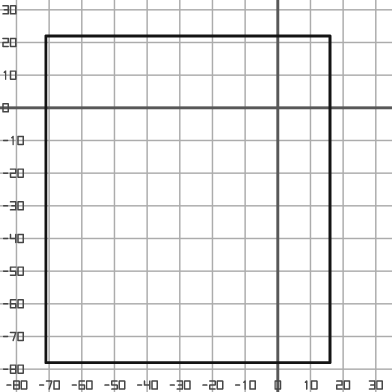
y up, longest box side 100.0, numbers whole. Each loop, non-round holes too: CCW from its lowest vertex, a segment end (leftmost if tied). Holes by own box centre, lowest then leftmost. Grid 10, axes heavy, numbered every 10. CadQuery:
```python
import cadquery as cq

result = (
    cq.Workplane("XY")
    .moveTo(-71.0, -78.0)
    .lineTo(16.0, -78.0)
    .lineTo(16.0, 22.0)
    .lineTo(-71.0, 22.0)
    .close()
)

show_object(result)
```